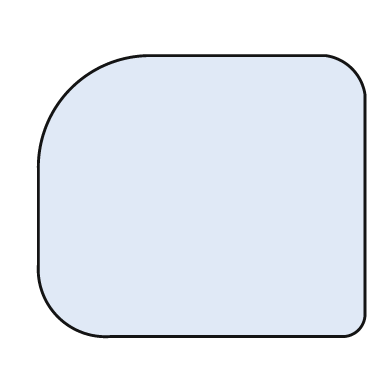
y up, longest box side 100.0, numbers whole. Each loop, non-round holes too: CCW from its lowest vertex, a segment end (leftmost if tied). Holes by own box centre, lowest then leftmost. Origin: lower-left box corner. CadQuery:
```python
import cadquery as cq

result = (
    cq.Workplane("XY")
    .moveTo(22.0, 0.0)
    .lineTo(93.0, 0.0)
    .threePointArc((98.0, 2.0), (100.0, 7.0))
    .lineTo(100.0, 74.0)
    .threePointArc((96.0, 82.0), (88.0, 86.0))
    .lineTo(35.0, 86.0)
    .threePointArc((10.0, 76.0), (0.0, 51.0))
    .lineTo(0.0, 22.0)
    .threePointArc((6.0, 6.0), (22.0, 0.0))
    .close()
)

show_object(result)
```